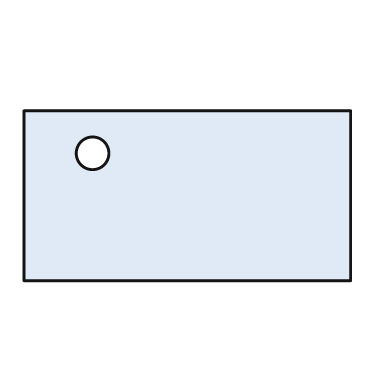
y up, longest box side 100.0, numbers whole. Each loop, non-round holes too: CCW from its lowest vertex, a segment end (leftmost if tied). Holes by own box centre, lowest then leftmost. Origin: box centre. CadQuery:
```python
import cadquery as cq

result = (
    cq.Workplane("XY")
    .moveTo(-50.0, -26.0)
    .lineTo(50.0, -26.0)
    .lineTo(50.0, 26.0)
    .lineTo(-50.0, 26.0)
    .close()
    .moveTo(-29.0, 13.0)
    .circle(5.0)
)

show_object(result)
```